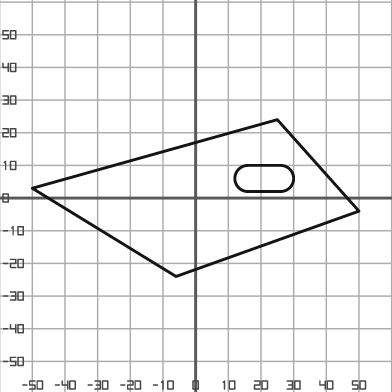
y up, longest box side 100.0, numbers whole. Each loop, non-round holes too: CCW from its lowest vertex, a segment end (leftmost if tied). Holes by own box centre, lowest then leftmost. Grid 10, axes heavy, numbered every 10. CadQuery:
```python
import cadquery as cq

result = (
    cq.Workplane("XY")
    .moveTo(-6.0, -24.0)
    .lineTo(50.0, -4.0)
    .lineTo(25.0, 24.0)
    .lineTo(-50.0, 3.0)
    .close()
    .moveTo(16.0, 2.0)
    .lineTo(26.0, 2.0)
    .threePointArc((30.0, 6.0), (26.0, 10.0))
    .lineTo(16.0, 10.0)
    .threePointArc((12.0, 6.0), (16.0, 2.0))
    .close()
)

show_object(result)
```